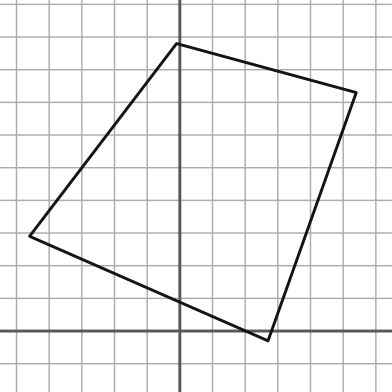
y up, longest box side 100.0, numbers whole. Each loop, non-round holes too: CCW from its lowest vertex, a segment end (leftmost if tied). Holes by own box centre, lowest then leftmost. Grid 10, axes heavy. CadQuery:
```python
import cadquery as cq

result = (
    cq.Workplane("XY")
    .moveTo(27.0, -3.0)
    .lineTo(54.0, 73.0)
    .lineTo(-1.0, 88.0)
    .lineTo(-46.0, 29.0)
    .close()
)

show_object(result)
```